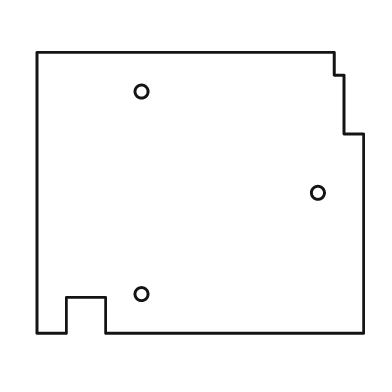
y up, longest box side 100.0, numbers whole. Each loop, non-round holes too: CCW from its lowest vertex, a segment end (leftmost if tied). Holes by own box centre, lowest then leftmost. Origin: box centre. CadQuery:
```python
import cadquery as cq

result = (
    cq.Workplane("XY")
    .moveTo(-50.0, -43.0)
    .lineTo(-41.0, -43.0)
    .lineTo(-41.0, -32.0)
    .lineTo(-29.0, -32.0)
    .lineTo(-29.0, -43.0)
    .lineTo(50.0, -43.0)
    .lineTo(50.0, 18.0)
    .lineTo(44.0, 18.0)
    .lineTo(44.0, 36.0)
    .lineTo(41.0, 36.0)
    .lineTo(41.0, 43.0)
    .lineTo(-50.0, 43.0)
    .close()
    .moveTo(-18.0, -31.0)
    .circle(2.0)
    .moveTo(36.0, 0.0)
    .circle(2.0)
    .moveTo(-18.0, 31.0)
    .circle(2.0)
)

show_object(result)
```